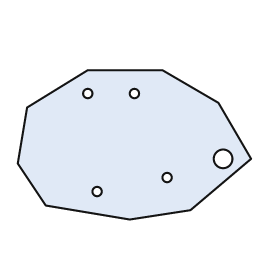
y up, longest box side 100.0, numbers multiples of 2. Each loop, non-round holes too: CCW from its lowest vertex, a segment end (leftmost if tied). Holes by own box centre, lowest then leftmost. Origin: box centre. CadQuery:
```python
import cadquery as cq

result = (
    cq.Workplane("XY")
    .moveTo(-2.0, -32.0)
    .lineTo(24.0, -28.0)
    .lineTo(50.0, -6.0)
    .lineTo(36.0, 18.0)
    .lineTo(12.0, 32.0)
    .lineTo(-20.0, 32.0)
    .lineTo(-46.0, 16.0)
    .lineTo(-50.0, -8.0)
    .lineTo(-38.0, -26.0)
    .close()
    .moveTo(-16.0, -20.0)
    .circle(2.0)
    .moveTo(14.0, -14.0)
    .circle(2.0)
    .moveTo(38.0, -6.0)
    .circle(4.0)
    .moveTo(-20.0, 22.0)
    .circle(2.0)
    .moveTo(0.0, 22.0)
    .circle(2.0)
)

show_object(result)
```